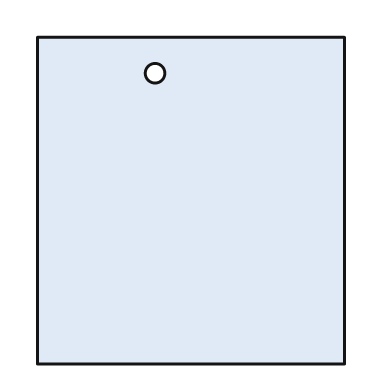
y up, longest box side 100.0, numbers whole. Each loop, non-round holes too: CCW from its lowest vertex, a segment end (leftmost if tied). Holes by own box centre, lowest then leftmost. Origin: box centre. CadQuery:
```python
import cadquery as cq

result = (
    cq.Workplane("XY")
    .moveTo(-47.0, -50.0)
    .lineTo(47.0, -50.0)
    .lineTo(47.0, 50.0)
    .lineTo(-47.0, 50.0)
    .close()
    .moveTo(-11.0, 39.0)
    .circle(3.0)
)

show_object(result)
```